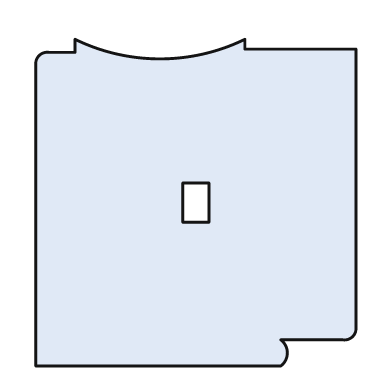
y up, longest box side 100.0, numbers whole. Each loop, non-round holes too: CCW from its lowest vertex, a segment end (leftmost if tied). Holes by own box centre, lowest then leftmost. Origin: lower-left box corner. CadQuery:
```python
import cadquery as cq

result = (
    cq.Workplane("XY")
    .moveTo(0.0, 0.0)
    .lineTo(75.0, 0.0)
    .threePointArc((77.0, 4.0), (75.0, 8.0))
    .lineTo(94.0, 8.0)
    .threePointArc((97.0, 9.0), (98.0, 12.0))
    .lineTo(98.0, 97.0)
    .lineTo(64.0, 97.0)
    .lineTo(64.0, 100.0)
    .threePointArc((38.0, 94.0), (12.0, 100.0))
    .lineTo(12.0, 96.0)
    .lineTo(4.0, 96.0)
    .threePointArc((1.0, 95.0), (0.0, 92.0))
    .close()
    .moveTo(45.0, 44.0)
    .lineTo(53.0, 44.0)
    .lineTo(53.0, 56.0)
    .lineTo(45.0, 56.0)
    .close()
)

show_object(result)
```